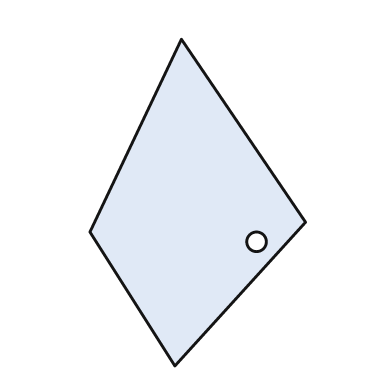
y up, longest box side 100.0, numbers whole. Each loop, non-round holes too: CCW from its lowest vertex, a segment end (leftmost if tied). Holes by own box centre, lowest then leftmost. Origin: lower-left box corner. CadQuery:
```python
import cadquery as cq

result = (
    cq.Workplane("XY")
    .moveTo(26.0, 0.0)
    .lineTo(66.0, 44.0)
    .lineTo(28.0, 100.0)
    .lineTo(0.0, 41.0)
    .close()
    .moveTo(51.0, 38.0)
    .circle(3.0)
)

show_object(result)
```